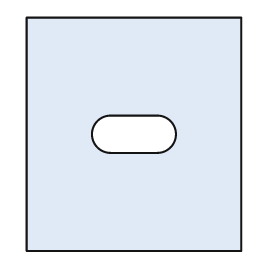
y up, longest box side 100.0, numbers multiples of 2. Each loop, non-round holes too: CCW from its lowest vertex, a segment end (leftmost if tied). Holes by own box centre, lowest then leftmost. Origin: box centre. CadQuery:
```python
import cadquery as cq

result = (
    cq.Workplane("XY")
    .moveTo(-46.0, -50.0)
    .lineTo(46.0, -50.0)
    .lineTo(46.0, 50.0)
    .lineTo(-46.0, 50.0)
    .close()
    .moveTo(-10.0, -8.0)
    .lineTo(10.0, -8.0)
    .threePointArc((18.0, 0.0), (10.0, 8.0))
    .lineTo(-10.0, 8.0)
    .threePointArc((-18.0, 0.0), (-10.0, -8.0))
    .close()
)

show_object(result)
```